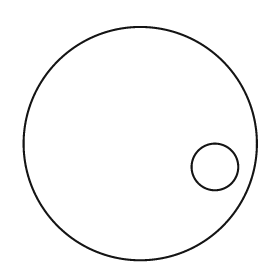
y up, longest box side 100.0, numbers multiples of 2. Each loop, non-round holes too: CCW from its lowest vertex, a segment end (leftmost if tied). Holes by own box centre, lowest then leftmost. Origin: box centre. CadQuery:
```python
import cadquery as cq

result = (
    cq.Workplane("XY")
    .moveTo(0.0, 0.0)
    .circle(50.0)
    .moveTo(32.0, -10.0)
    .circle(10.0)
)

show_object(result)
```